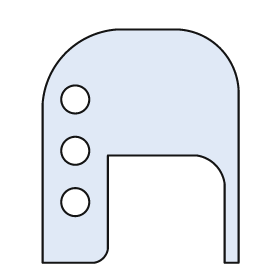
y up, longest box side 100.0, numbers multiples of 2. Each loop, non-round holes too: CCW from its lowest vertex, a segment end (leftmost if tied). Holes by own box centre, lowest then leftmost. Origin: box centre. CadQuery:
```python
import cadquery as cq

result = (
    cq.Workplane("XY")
    .moveTo(-42.0, -50.0)
    .lineTo(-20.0, -50.0)
    .threePointArc((-16.0, -48.0), (-14.0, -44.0))
    .lineTo(-14.0, -4.0)
    .lineTo(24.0, -4.0)
    .threePointArc((32.0, -8.0), (36.0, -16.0))
    .lineTo(36.0, -50.0)
    .lineTo(42.0, -50.0)
    .lineTo(42.0, 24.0)
    .threePointArc((34.0, 42.0), (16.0, 50.0))
    .lineTo(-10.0, 50.0)
    .threePointArc((-32.0, 40.0), (-42.0, 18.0))
    .close()
    .moveTo(-28.0, -24.0)
    .circle(6.0)
    .moveTo(-28.0, -2.0)
    .circle(6.0)
    .moveTo(-28.0, 20.0)
    .circle(6.0)
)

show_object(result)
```